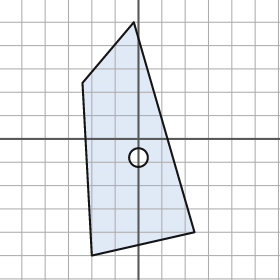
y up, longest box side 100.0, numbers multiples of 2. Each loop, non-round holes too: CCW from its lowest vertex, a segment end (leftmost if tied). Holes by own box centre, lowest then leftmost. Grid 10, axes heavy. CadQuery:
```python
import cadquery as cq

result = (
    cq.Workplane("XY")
    .moveTo(-20.0, -50.0)
    .lineTo(24.0, -40.0)
    .lineTo(-2.0, 50.0)
    .lineTo(-24.0, 24.0)
    .close()
    .moveTo(0.0, -8.0)
    .circle(4.0)
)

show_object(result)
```